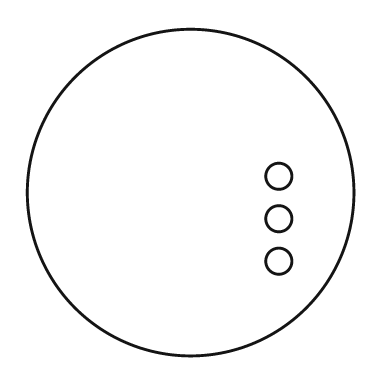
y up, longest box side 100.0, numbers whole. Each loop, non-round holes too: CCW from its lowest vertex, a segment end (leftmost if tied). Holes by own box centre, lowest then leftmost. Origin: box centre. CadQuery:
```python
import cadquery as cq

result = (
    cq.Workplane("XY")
    .moveTo(0.0, 0.0)
    .circle(50.0)
    .moveTo(27.0, -21.0)
    .circle(4.0)
    .moveTo(27.0, -8.0)
    .circle(4.0)
    .moveTo(27.0, 5.0)
    .circle(4.0)
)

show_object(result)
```